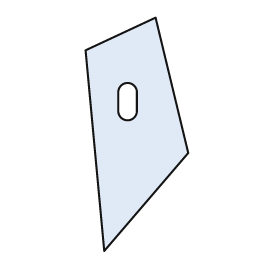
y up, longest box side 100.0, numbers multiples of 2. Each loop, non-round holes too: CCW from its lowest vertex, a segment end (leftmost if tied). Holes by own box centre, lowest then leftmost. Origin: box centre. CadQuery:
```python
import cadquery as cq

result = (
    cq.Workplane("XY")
    .moveTo(-14.0, -50.0)
    .lineTo(22.0, -8.0)
    .lineTo(8.0, 50.0)
    .lineTo(-22.0, 36.0)
    .close()
    .moveTo(-8.0, 10.0)
    .threePointArc((-4.0, 6.0), (0.0, 10.0))
    .lineTo(0.0, 18.0)
    .threePointArc((-4.0, 22.0), (-8.0, 18.0))
    .close()
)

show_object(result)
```